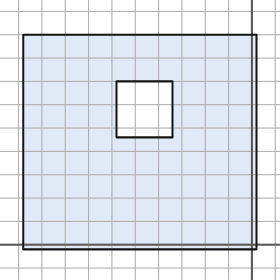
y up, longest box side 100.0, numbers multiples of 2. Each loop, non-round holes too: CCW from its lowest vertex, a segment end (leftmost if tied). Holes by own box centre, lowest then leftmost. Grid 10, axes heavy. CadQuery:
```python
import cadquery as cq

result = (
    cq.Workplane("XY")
    .moveTo(-98.0, -2.0)
    .lineTo(2.0, -2.0)
    .lineTo(2.0, 90.0)
    .lineTo(-98.0, 90.0)
    .close()
    .moveTo(-58.0, 46.0)
    .lineTo(-34.0, 46.0)
    .lineTo(-34.0, 70.0)
    .lineTo(-58.0, 70.0)
    .close()
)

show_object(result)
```